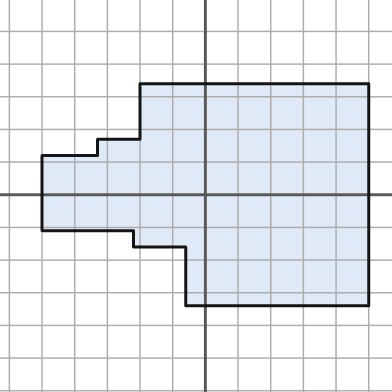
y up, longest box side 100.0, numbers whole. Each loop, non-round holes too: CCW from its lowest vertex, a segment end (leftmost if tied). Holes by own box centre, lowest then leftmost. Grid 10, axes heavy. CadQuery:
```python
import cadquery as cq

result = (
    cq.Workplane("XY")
    .moveTo(-6.0, -34.0)
    .lineTo(50.0, -34.0)
    .lineTo(50.0, 34.0)
    .lineTo(-20.0, 34.0)
    .lineTo(-20.0, 17.0)
    .lineTo(-33.0, 17.0)
    .lineTo(-33.0, 12.0)
    .lineTo(-50.0, 12.0)
    .lineTo(-50.0, -11.0)
    .lineTo(-22.0, -11.0)
    .lineTo(-22.0, -16.0)
    .lineTo(-6.0, -16.0)
    .close()
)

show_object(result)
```